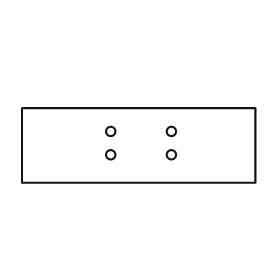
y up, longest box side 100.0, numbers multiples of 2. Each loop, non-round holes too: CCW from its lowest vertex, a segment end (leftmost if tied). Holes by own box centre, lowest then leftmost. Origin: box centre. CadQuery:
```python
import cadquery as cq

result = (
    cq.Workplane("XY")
    .moveTo(-50.0, -16.0)
    .lineTo(50.0, -16.0)
    .lineTo(50.0, 16.0)
    .lineTo(-50.0, 16.0)
    .close()
    .moveTo(-12.0, -4.0)
    .circle(2.0)
    .moveTo(14.0, -4.0)
    .circle(2.0)
    .moveTo(-12.0, 6.0)
    .circle(2.0)
    .moveTo(14.0, 6.0)
    .circle(2.0)
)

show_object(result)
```